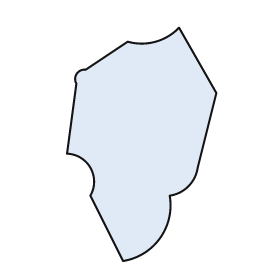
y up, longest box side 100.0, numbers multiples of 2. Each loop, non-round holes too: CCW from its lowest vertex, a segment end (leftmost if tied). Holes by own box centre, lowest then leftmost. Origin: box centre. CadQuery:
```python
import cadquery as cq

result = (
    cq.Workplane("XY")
    .moveTo(-8.0, -50.0)
    .threePointArc((8.0, -40.0), (12.0, -22.0))
    .threePointArc((20.0, -18.0), (24.0, -10.0))
    .lineTo(32.0, 22.0)
    .lineTo(16.0, 50.0)
    .threePointArc((6.0, 44.0), (-6.0, 44.0))
    .lineTo(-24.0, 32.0)
    .threePointArc((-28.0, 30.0), (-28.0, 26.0))
    .lineTo(-32.0, -4.0)
    .threePointArc((-22.0, -10.0), (-22.0, -22.0))
    .close()
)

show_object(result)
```